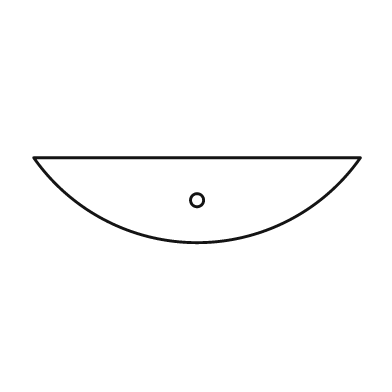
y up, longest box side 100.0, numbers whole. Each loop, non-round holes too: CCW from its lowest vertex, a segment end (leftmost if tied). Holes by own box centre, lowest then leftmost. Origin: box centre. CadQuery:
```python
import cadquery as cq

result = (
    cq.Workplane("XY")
    .moveTo(-50.0, 13.0)
    .threePointArc((0.0, -13.0), (50.0, 13.0))
    .close()
    .moveTo(0.0, 0.0)
    .circle(2.0)
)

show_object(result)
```